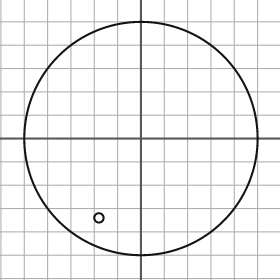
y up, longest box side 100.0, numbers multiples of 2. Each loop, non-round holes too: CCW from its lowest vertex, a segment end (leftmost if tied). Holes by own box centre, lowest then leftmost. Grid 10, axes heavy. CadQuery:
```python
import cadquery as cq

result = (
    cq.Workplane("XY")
    .moveTo(0.0, 0.0)
    .circle(50.0)
    .moveTo(-18.0, -34.0)
    .circle(2.0)
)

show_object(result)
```